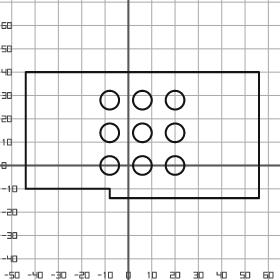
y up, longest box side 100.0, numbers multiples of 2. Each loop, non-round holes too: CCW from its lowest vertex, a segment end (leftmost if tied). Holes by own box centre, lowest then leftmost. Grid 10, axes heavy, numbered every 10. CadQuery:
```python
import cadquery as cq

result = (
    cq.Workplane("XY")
    .moveTo(-8.0, -14.0)
    .lineTo(56.0, -14.0)
    .lineTo(56.0, 40.0)
    .lineTo(-44.0, 40.0)
    .lineTo(-44.0, -10.0)
    .lineTo(-8.0, -10.0)
    .close()
    .moveTo(-8.0, 0.0)
    .circle(4.0)
    .moveTo(6.0, 0.0)
    .circle(4.0)
    .moveTo(20.0, 0.0)
    .circle(4.0)
    .moveTo(-8.0, 14.0)
    .circle(4.0)
    .moveTo(6.0, 14.0)
    .circle(4.0)
    .moveTo(20.0, 14.0)
    .circle(4.0)
    .moveTo(-8.0, 28.0)
    .circle(4.0)
    .moveTo(6.0, 28.0)
    .circle(4.0)
    .moveTo(20.0, 28.0)
    .circle(4.0)
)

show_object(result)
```